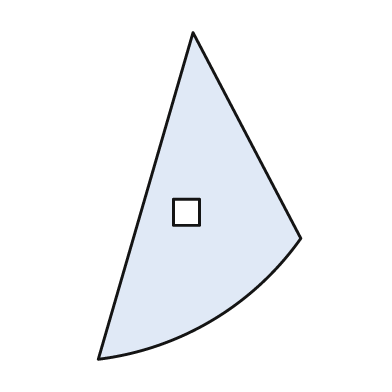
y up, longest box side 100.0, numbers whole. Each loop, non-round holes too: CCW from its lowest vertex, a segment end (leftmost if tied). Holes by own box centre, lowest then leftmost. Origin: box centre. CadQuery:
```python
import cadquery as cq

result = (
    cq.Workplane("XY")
    .moveTo(-31.0, -50.0)
    .threePointArc((4.0, -38.0), (31.0, -13.0))
    .lineTo(-2.0, 50.0)
    .close()
    .moveTo(-8.0, -9.0)
    .lineTo(0.0, -9.0)
    .lineTo(0.0, -1.0)
    .lineTo(-8.0, -1.0)
    .close()
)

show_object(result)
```